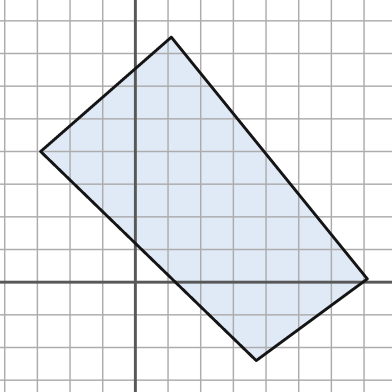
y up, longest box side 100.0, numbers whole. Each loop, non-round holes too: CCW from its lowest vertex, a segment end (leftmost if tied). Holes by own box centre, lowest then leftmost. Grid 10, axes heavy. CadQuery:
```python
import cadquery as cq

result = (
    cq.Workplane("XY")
    .moveTo(37.0, -24.0)
    .lineTo(71.0, 1.0)
    .lineTo(11.0, 75.0)
    .lineTo(-29.0, 40.0)
    .close()
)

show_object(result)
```